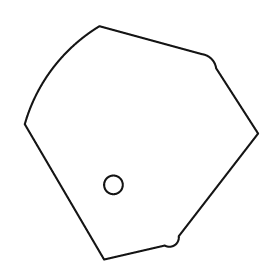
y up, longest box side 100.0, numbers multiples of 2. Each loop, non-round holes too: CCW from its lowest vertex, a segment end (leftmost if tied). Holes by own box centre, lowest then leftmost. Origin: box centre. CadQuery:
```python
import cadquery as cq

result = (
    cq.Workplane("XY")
    .moveTo(-16.0, -50.0)
    .lineTo(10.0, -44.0)
    .threePointArc((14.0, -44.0), (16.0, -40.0))
    .lineTo(50.0, 4.0)
    .lineTo(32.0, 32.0)
    .threePointArc((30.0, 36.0), (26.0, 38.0))
    .lineTo(-18.0, 50.0)
    .threePointArc((-38.0, 32.0), (-50.0, 8.0))
    .close()
    .moveTo(-12.0, -18.0)
    .circle(4.0)
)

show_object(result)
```